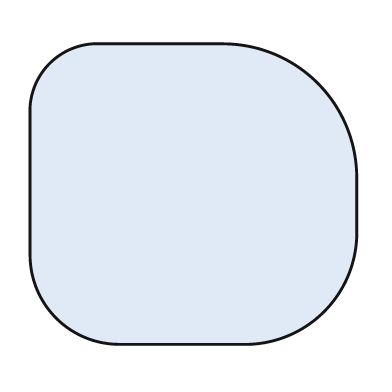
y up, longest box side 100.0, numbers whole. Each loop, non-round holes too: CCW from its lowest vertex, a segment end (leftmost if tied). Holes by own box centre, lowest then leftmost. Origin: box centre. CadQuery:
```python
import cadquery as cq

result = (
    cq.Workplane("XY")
    .moveTo(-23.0, -46.0)
    .lineTo(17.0, -46.0)
    .threePointArc((40.0, -36.0), (50.0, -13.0))
    .lineTo(50.0, 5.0)
    .threePointArc((38.0, 34.0), (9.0, 46.0))
    .lineTo(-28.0, 46.0)
    .threePointArc((-44.0, 40.0), (-50.0, 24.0))
    .lineTo(-50.0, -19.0)
    .threePointArc((-42.0, -38.0), (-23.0, -46.0))
    .close()
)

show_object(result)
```